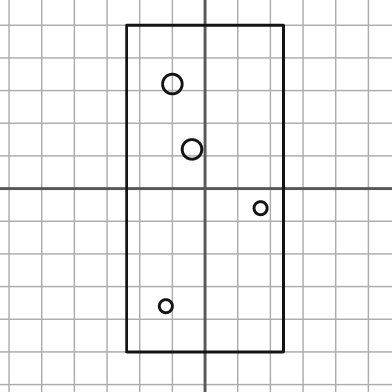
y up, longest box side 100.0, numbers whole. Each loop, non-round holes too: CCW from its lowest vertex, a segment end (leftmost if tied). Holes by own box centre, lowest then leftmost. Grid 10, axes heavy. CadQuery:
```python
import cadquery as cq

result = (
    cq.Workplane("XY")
    .moveTo(-24.0, -50.0)
    .lineTo(24.0, -50.0)
    .lineTo(24.0, 50.0)
    .lineTo(-24.0, 50.0)
    .close()
    .moveTo(-12.0, -36.0)
    .circle(2.0)
    .moveTo(17.0, -6.0)
    .circle(2.0)
    .moveTo(-4.0, 12.0)
    .circle(3.0)
    .moveTo(-10.0, 32.0)
    .circle(3.0)
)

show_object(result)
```